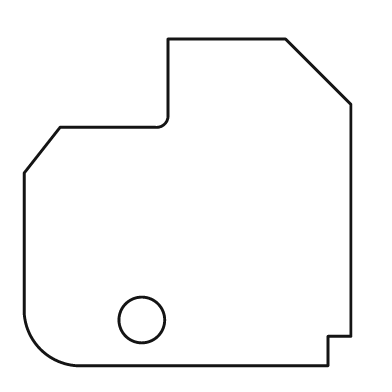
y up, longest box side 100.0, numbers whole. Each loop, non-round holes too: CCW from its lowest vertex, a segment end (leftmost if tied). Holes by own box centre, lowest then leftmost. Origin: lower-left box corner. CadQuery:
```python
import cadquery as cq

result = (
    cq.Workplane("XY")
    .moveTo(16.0, 0.0)
    .lineTo(93.0, 0.0)
    .lineTo(93.0, 9.0)
    .lineTo(100.0, 9.0)
    .lineTo(100.0, 80.0)
    .lineTo(80.0, 100.0)
    .lineTo(44.0, 100.0)
    .lineTo(44.0, 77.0)
    .threePointArc((43.0, 74.0), (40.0, 73.0))
    .lineTo(11.0, 73.0)
    .lineTo(0.0, 59.0)
    .lineTo(0.0, 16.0)
    .threePointArc((5.0, 5.0), (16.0, 0.0))
    .close()
    .moveTo(36.0, 14.0)
    .circle(7.0)
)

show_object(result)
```